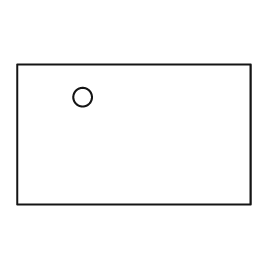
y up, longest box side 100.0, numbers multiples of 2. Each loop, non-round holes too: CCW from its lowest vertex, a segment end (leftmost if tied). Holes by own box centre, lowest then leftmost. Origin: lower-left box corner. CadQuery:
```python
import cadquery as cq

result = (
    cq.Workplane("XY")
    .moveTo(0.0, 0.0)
    .lineTo(100.0, 0.0)
    .lineTo(100.0, 60.0)
    .lineTo(0.0, 60.0)
    .close()
    .moveTo(28.0, 46.0)
    .circle(4.0)
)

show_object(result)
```